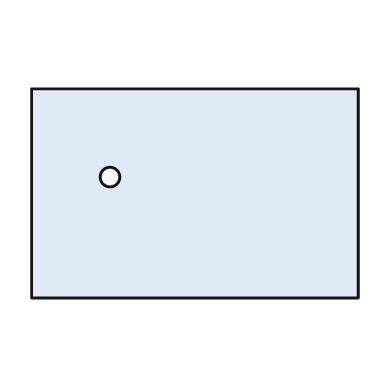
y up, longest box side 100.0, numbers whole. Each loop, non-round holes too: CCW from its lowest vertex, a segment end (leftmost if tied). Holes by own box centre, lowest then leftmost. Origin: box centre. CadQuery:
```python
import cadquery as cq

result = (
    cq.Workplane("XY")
    .moveTo(-50.0, -32.0)
    .lineTo(50.0, -32.0)
    .lineTo(50.0, 32.0)
    .lineTo(-50.0, 32.0)
    .close()
    .moveTo(-26.0, 5.0)
    .circle(3.0)
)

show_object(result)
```